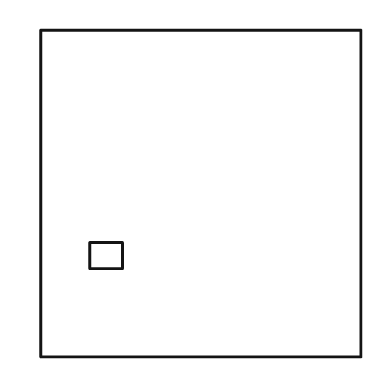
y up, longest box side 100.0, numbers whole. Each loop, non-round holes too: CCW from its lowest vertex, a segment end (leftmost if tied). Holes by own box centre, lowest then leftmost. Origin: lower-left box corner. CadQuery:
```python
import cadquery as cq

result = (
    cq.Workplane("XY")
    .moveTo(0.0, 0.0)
    .lineTo(98.0, 0.0)
    .lineTo(98.0, 100.0)
    .lineTo(0.0, 100.0)
    .close()
    .moveTo(15.0, 27.0)
    .lineTo(25.0, 27.0)
    .lineTo(25.0, 35.0)
    .lineTo(15.0, 35.0)
    .close()
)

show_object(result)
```